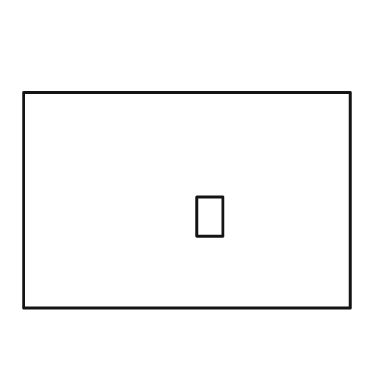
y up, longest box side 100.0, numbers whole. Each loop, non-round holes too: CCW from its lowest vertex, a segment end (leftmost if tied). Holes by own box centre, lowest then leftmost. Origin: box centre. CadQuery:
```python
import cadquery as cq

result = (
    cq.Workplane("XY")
    .moveTo(-50.0, -33.0)
    .lineTo(50.0, -33.0)
    .lineTo(50.0, 33.0)
    .lineTo(-50.0, 33.0)
    .close()
    .moveTo(3.0, -11.0)
    .lineTo(11.0, -11.0)
    .lineTo(11.0, 1.0)
    .lineTo(3.0, 1.0)
    .close()
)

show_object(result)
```